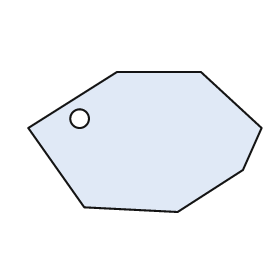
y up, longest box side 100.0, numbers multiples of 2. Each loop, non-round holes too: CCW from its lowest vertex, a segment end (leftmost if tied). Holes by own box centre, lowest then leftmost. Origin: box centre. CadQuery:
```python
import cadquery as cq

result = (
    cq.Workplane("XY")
    .moveTo(14.0, -30.0)
    .lineTo(42.0, -12.0)
    .lineTo(50.0, 6.0)
    .lineTo(24.0, 30.0)
    .lineTo(-12.0, 30.0)
    .lineTo(-50.0, 6.0)
    .lineTo(-26.0, -28.0)
    .close()
    .moveTo(-28.0, 10.0)
    .circle(4.0)
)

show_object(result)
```